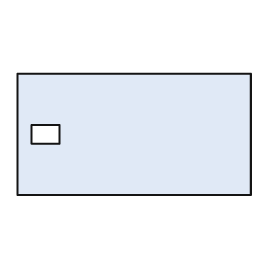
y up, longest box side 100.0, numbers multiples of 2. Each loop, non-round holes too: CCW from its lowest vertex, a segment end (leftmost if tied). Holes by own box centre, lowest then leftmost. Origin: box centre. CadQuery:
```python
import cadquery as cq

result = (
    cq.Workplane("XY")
    .moveTo(-50.0, -26.0)
    .lineTo(50.0, -26.0)
    .lineTo(50.0, 26.0)
    .lineTo(-50.0, 26.0)
    .close()
    .moveTo(-44.0, -4.0)
    .lineTo(-32.0, -4.0)
    .lineTo(-32.0, 4.0)
    .lineTo(-44.0, 4.0)
    .close()
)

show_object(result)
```